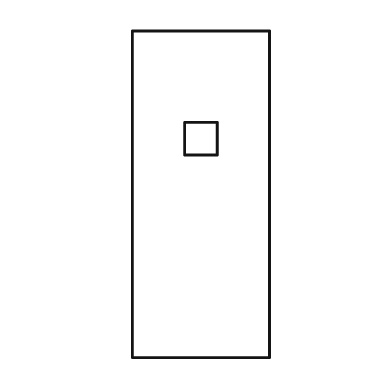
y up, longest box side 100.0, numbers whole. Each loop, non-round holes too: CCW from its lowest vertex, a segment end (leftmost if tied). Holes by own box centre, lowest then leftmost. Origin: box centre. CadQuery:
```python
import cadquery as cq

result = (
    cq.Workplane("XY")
    .moveTo(-21.0, -50.0)
    .lineTo(21.0, -50.0)
    .lineTo(21.0, 50.0)
    .lineTo(-21.0, 50.0)
    .close()
    .moveTo(-5.0, 12.0)
    .lineTo(5.0, 12.0)
    .lineTo(5.0, 22.0)
    .lineTo(-5.0, 22.0)
    .close()
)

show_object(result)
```